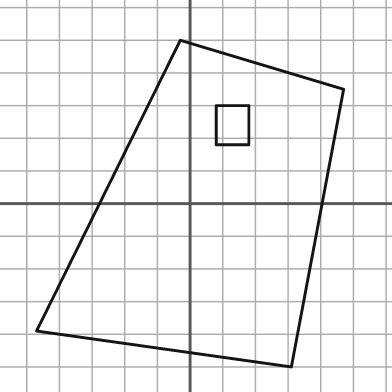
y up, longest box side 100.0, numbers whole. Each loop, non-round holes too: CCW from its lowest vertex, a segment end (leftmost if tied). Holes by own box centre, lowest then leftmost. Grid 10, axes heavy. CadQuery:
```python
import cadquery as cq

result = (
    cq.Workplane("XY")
    .moveTo(31.0, -50.0)
    .lineTo(47.0, 35.0)
    .lineTo(-3.0, 50.0)
    .lineTo(-47.0, -39.0)
    .close()
    .moveTo(8.0, 18.0)
    .lineTo(18.0, 18.0)
    .lineTo(18.0, 30.0)
    .lineTo(8.0, 30.0)
    .close()
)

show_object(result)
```